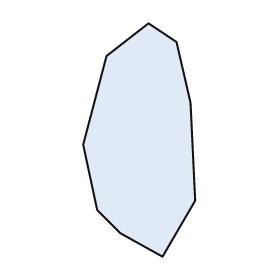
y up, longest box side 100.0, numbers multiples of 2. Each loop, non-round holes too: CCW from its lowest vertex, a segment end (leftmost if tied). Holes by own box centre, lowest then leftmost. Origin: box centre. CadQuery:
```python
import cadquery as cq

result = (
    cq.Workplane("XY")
    .moveTo(10.0, -50.0)
    .lineTo(24.0, -26.0)
    .lineTo(22.0, 16.0)
    .lineTo(16.0, 42.0)
    .lineTo(4.0, 50.0)
    .lineTo(-14.0, 36.0)
    .lineTo(-24.0, -2.0)
    .lineTo(-18.0, -30.0)
    .lineTo(-8.0, -40.0)
    .close()
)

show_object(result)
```